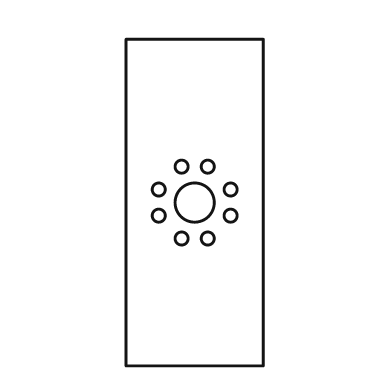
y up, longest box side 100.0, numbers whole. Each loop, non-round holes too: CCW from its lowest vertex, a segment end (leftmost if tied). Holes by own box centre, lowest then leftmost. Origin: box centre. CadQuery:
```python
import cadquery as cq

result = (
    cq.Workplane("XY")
    .moveTo(-21.0, -50.0)
    .lineTo(21.0, -50.0)
    .lineTo(21.0, 50.0)
    .lineTo(-21.0, 50.0)
    .close()
    .moveTo(-4.0, -11.0)
    .circle(2.0)
    .moveTo(4.0, -11.0)
    .circle(2.0)
    .moveTo(-11.0, -4.0)
    .circle(2.0)
    .moveTo(11.0, -4.0)
    .circle(2.0)
    .moveTo(0.0, 0.0)
    .circle(6.0)
    .moveTo(-11.0, 4.0)
    .circle(2.0)
    .moveTo(11.0, 4.0)
    .circle(2.0)
    .moveTo(-4.0, 11.0)
    .circle(2.0)
    .moveTo(4.0, 11.0)
    .circle(2.0)
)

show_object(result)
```